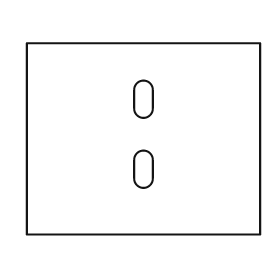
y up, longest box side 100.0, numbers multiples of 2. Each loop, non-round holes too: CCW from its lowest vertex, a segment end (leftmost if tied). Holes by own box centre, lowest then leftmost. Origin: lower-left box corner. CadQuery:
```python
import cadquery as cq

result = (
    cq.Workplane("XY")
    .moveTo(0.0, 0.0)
    .lineTo(100.0, 0.0)
    .lineTo(100.0, 82.0)
    .lineTo(0.0, 82.0)
    .close()
    .moveTo(46.0, 24.0)
    .threePointArc((50.0, 20.0), (54.0, 24.0))
    .lineTo(54.0, 32.0)
    .threePointArc((50.0, 36.0), (46.0, 32.0))
    .close()
    .moveTo(46.0, 54.0)
    .threePointArc((50.0, 50.0), (54.0, 54.0))
    .lineTo(54.0, 62.0)
    .threePointArc((50.0, 66.0), (46.0, 62.0))
    .close()
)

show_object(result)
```